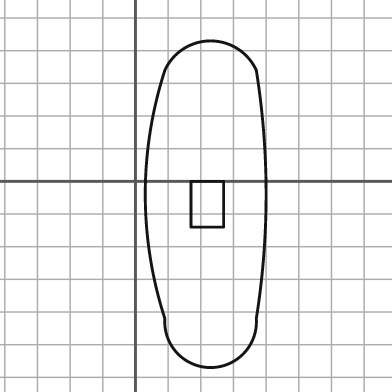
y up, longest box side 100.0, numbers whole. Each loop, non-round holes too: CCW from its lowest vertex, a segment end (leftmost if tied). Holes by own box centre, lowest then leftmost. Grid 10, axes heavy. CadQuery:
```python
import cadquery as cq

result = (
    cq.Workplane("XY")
    .moveTo(9.0, -42.0)
    .threePointArc((23.0, -57.0), (37.0, -42.0))
    .threePointArc((40.0, -4.0), (37.0, 34.0))
    .threePointArc((23.0, 43.0), (9.0, 34.0))
    .threePointArc((3.0, -4.0), (9.0, -42.0))
    .close()
    .moveTo(17.0, -14.0)
    .lineTo(27.0, -14.0)
    .lineTo(27.0, 0.0)
    .lineTo(17.0, 0.0)
    .close()
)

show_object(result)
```